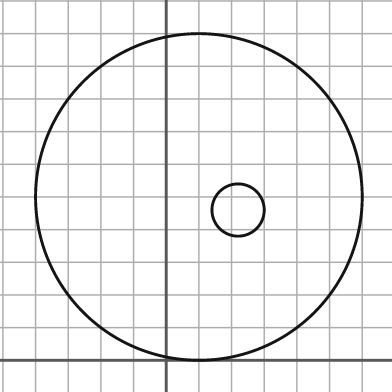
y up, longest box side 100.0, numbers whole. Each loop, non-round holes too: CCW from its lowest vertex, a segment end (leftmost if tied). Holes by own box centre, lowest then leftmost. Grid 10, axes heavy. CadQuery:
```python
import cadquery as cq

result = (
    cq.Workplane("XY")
    .moveTo(10.0, 50.0)
    .circle(50.0)
    .moveTo(22.0, 46.0)
    .circle(8.0)
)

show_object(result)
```